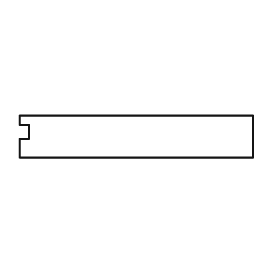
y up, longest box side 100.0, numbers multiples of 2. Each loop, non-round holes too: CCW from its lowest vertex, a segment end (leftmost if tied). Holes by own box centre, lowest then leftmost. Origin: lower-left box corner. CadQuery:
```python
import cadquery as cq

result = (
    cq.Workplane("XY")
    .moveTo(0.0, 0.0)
    .lineTo(100.0, 0.0)
    .lineTo(100.0, 18.0)
    .lineTo(0.0, 18.0)
    .lineTo(0.0, 14.0)
    .lineTo(4.0, 14.0)
    .lineTo(4.0, 8.0)
    .lineTo(0.0, 8.0)
    .close()
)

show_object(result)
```